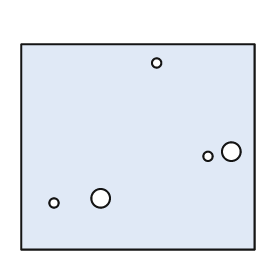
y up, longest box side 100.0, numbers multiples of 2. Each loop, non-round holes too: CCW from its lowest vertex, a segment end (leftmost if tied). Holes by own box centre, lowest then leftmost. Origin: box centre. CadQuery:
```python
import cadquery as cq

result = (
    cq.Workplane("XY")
    .moveTo(-50.0, -44.0)
    .lineTo(50.0, -44.0)
    .lineTo(50.0, 44.0)
    .lineTo(-50.0, 44.0)
    .close()
    .moveTo(-36.0, -24.0)
    .circle(2.0)
    .moveTo(-16.0, -22.0)
    .circle(4.0)
    .moveTo(30.0, -4.0)
    .circle(2.0)
    .moveTo(40.0, -2.0)
    .circle(4.0)
    .moveTo(8.0, 36.0)
    .circle(2.0)
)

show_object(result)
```